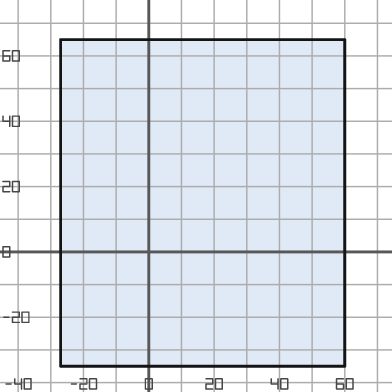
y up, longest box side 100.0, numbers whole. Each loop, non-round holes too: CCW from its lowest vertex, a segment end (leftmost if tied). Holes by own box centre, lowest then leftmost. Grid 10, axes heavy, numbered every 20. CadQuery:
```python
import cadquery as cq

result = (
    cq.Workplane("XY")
    .moveTo(-27.0, -35.0)
    .lineTo(60.0, -35.0)
    .lineTo(60.0, 65.0)
    .lineTo(-27.0, 65.0)
    .close()
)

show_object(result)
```